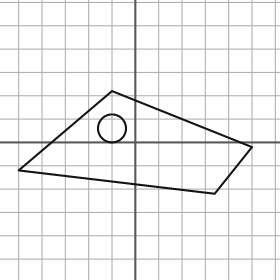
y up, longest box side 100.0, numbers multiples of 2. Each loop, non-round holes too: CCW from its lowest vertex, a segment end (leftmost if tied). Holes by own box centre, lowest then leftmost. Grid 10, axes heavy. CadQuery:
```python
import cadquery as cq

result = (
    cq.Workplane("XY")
    .moveTo(34.0, -22.0)
    .lineTo(50.0, -2.0)
    .lineTo(-10.0, 22.0)
    .lineTo(-50.0, -12.0)
    .close()
    .moveTo(-10.0, 6.0)
    .circle(6.0)
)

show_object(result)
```